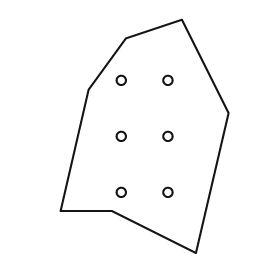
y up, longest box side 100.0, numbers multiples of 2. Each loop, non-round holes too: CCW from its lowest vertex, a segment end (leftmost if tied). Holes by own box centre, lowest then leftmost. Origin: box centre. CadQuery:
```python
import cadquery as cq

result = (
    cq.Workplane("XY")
    .moveTo(22.0, -50.0)
    .lineTo(36.0, 10.0)
    .lineTo(16.0, 50.0)
    .lineTo(-8.0, 42.0)
    .lineTo(-24.0, 20.0)
    .lineTo(-36.0, -32.0)
    .lineTo(-14.0, -32.0)
    .close()
    .moveTo(-10.0, -24.0)
    .circle(2.0)
    .moveTo(10.0, -24.0)
    .circle(2.0)
    .moveTo(-10.0, 0.0)
    .circle(2.0)
    .moveTo(10.0, 0.0)
    .circle(2.0)
    .moveTo(-10.0, 24.0)
    .circle(2.0)
    .moveTo(10.0, 24.0)
    .circle(2.0)
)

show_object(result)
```